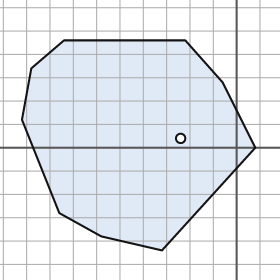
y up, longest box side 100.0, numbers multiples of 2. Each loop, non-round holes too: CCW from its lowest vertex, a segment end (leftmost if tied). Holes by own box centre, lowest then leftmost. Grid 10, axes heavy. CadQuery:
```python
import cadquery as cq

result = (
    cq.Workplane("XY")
    .moveTo(-32.0, -44.0)
    .lineTo(8.0, 0.0)
    .lineTo(-6.0, 28.0)
    .lineTo(-22.0, 46.0)
    .lineTo(-74.0, 46.0)
    .lineTo(-88.0, 34.0)
    .lineTo(-92.0, 12.0)
    .lineTo(-76.0, -28.0)
    .lineTo(-58.0, -38.0)
    .close()
    .moveTo(-24.0, 4.0)
    .circle(2.0)
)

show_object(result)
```